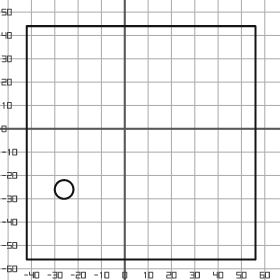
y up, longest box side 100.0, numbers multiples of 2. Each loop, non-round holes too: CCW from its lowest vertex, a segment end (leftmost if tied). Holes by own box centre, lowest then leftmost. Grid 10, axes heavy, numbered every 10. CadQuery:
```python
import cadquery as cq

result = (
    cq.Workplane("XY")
    .moveTo(-42.0, -56.0)
    .lineTo(56.0, -56.0)
    .lineTo(56.0, 44.0)
    .lineTo(-42.0, 44.0)
    .close()
    .moveTo(-26.0, -26.0)
    .circle(4.0)
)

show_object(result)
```